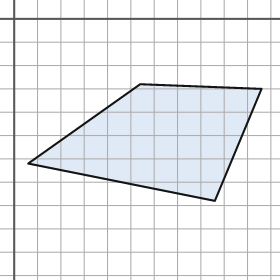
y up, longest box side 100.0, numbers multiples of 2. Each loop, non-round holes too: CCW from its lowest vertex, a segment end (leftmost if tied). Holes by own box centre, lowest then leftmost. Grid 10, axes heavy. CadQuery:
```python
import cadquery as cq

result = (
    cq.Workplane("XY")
    .moveTo(86.0, -78.0)
    .lineTo(106.0, -30.0)
    .lineTo(54.0, -28.0)
    .lineTo(6.0, -62.0)
    .close()
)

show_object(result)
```